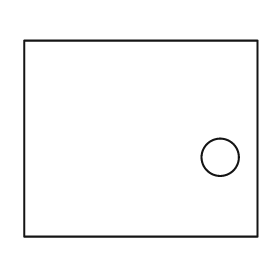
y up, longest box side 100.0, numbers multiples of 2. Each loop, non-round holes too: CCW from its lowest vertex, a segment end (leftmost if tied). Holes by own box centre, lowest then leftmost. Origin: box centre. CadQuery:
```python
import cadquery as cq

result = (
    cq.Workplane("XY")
    .moveTo(-50.0, -42.0)
    .lineTo(50.0, -42.0)
    .lineTo(50.0, 42.0)
    .lineTo(-50.0, 42.0)
    .close()
    .moveTo(34.0, -8.0)
    .circle(8.0)
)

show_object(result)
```